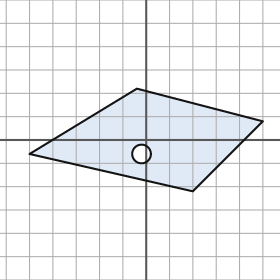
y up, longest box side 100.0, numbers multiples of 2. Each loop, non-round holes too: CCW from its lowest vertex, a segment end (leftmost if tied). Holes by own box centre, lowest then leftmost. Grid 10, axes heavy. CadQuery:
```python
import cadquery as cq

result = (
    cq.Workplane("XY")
    .moveTo(20.0, -22.0)
    .lineTo(50.0, 8.0)
    .lineTo(-4.0, 22.0)
    .lineTo(-50.0, -6.0)
    .close()
    .moveTo(-2.0, -6.0)
    .circle(4.0)
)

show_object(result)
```